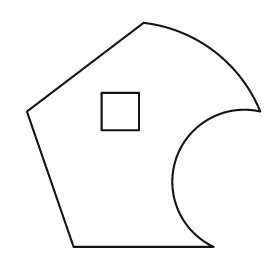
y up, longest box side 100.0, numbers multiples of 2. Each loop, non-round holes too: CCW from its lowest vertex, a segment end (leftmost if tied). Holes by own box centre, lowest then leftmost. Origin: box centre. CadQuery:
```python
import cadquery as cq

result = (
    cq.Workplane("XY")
    .moveTo(-30.0, -48.0)
    .lineTo(30.0, -48.0)
    .threePointArc((14.0, -10.0), (50.0, 10.0))
    .threePointArc((30.0, 36.0), (0.0, 48.0))
    .lineTo(-50.0, 10.0)
    .close()
    .moveTo(-18.0, 2.0)
    .lineTo(-2.0, 2.0)
    .lineTo(-2.0, 18.0)
    .lineTo(-18.0, 18.0)
    .close()
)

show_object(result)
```